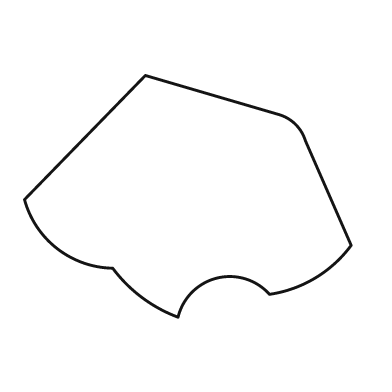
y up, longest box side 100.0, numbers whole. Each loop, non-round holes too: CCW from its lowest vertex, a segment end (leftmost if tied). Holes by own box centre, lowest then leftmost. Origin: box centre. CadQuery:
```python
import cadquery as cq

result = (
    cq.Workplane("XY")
    .moveTo(-3.0, -37.0)
    .threePointArc((9.0, -25.0), (25.0, -30.0))
    .threePointArc((39.0, -25.0), (50.0, -15.0))
    .lineTo(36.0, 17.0)
    .threePointArc((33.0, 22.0), (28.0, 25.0))
    .lineTo(-13.0, 37.0)
    .lineTo(-50.0, -1.0)
    .threePointArc((-40.0, -16.0), (-23.0, -22.0))
    .threePointArc((-14.0, -31.0), (-3.0, -37.0))
    .close()
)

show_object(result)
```